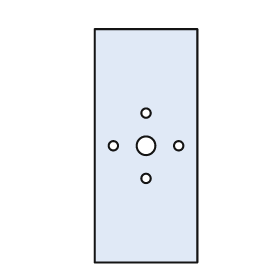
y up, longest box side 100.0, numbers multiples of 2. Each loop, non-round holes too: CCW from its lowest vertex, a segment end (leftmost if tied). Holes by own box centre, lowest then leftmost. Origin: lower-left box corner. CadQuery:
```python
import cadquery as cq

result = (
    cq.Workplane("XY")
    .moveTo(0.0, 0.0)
    .lineTo(44.0, 0.0)
    .lineTo(44.0, 100.0)
    .lineTo(0.0, 100.0)
    .close()
    .moveTo(22.0, 36.0)
    .circle(2.0)
    .moveTo(8.0, 50.0)
    .circle(2.0)
    .moveTo(22.0, 50.0)
    .circle(4.0)
    .moveTo(36.0, 50.0)
    .circle(2.0)
    .moveTo(22.0, 64.0)
    .circle(2.0)
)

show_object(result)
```